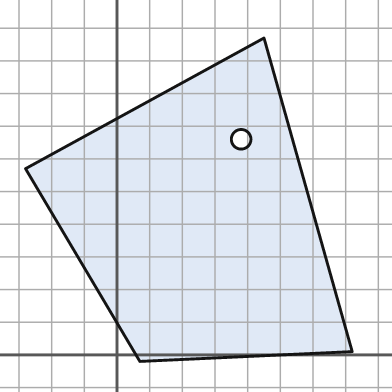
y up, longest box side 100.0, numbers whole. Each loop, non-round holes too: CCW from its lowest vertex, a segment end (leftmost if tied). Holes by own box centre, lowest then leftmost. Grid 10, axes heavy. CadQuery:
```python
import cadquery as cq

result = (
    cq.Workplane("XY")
    .moveTo(7.0, -2.0)
    .lineTo(72.0, 1.0)
    .lineTo(45.0, 97.0)
    .lineTo(-28.0, 57.0)
    .close()
    .moveTo(38.0, 66.0)
    .circle(3.0)
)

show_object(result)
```